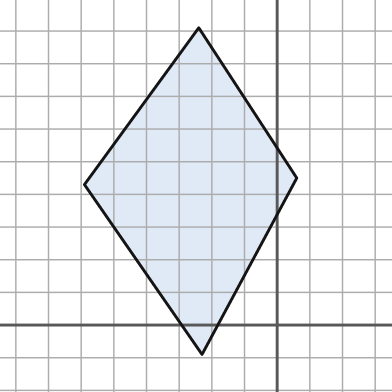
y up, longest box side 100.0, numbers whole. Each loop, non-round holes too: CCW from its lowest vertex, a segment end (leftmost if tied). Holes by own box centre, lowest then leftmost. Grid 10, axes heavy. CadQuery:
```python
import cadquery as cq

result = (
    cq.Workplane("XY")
    .moveTo(-23.0, -9.0)
    .lineTo(6.0, 45.0)
    .lineTo(-24.0, 91.0)
    .lineTo(-59.0, 43.0)
    .close()
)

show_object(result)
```